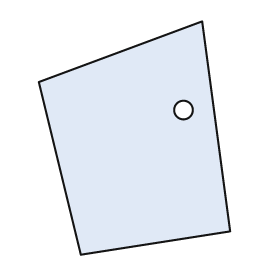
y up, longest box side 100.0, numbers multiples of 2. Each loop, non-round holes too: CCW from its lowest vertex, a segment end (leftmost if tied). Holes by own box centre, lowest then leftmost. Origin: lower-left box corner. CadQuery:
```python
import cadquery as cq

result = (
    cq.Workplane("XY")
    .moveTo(18.0, 0.0)
    .lineTo(82.0, 10.0)
    .lineTo(70.0, 100.0)
    .lineTo(0.0, 74.0)
    .close()
    .moveTo(62.0, 62.0)
    .circle(4.0)
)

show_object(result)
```